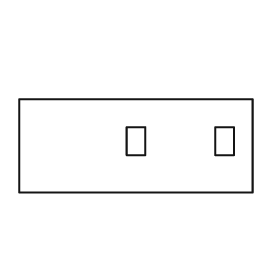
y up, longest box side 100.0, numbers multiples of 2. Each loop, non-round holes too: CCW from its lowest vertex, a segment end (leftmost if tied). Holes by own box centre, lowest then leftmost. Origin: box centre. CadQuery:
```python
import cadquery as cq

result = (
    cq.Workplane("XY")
    .moveTo(-50.0, -20.0)
    .lineTo(50.0, -20.0)
    .lineTo(50.0, 20.0)
    .lineTo(-50.0, 20.0)
    .close()
    .moveTo(-4.0, -4.0)
    .lineTo(4.0, -4.0)
    .lineTo(4.0, 8.0)
    .lineTo(-4.0, 8.0)
    .close()
    .moveTo(34.0, -4.0)
    .lineTo(42.0, -4.0)
    .lineTo(42.0, 8.0)
    .lineTo(34.0, 8.0)
    .close()
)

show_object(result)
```